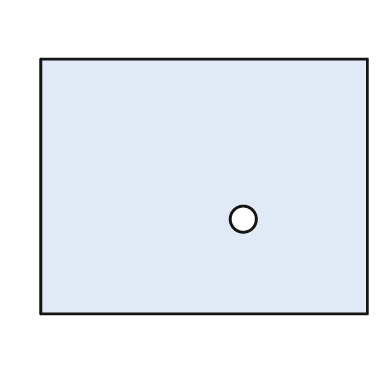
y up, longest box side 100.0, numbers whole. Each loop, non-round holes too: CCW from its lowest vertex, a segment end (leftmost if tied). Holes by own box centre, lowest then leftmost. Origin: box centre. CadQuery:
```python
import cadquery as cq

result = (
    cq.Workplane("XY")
    .moveTo(-50.0, -39.0)
    .lineTo(50.0, -39.0)
    .lineTo(50.0, 39.0)
    .lineTo(-50.0, 39.0)
    .close()
    .moveTo(12.0, -10.0)
    .circle(4.0)
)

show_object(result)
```